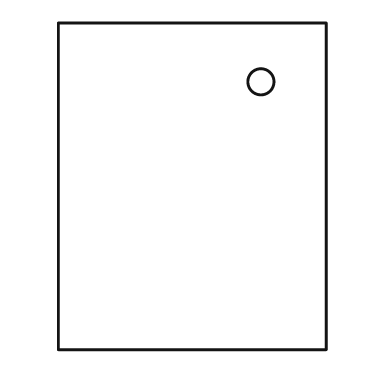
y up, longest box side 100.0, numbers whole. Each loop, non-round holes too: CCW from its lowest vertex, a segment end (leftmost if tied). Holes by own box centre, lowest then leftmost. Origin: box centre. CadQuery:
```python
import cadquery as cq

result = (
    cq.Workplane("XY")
    .moveTo(-41.0, -50.0)
    .lineTo(41.0, -50.0)
    .lineTo(41.0, 50.0)
    .lineTo(-41.0, 50.0)
    .close()
    .moveTo(21.0, 32.0)
    .circle(4.0)
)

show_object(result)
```